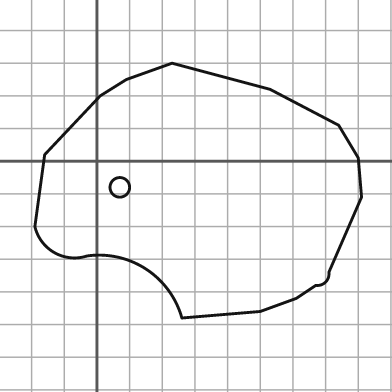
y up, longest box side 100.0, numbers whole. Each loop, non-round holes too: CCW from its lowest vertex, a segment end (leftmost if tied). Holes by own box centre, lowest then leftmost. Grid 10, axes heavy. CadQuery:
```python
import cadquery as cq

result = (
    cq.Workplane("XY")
    .moveTo(26.0, -48.0)
    .lineTo(50.0, -46.0)
    .lineTo(61.0, -42.0)
    .lineTo(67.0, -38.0)
    .threePointArc((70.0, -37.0), (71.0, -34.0))
    .lineTo(81.0, -11.0)
    .lineTo(80.0, 1.0)
    .lineTo(74.0, 11.0)
    .lineTo(53.0, 22.0)
    .lineTo(23.0, 30.0)
    .lineTo(9.0, 25.0)
    .lineTo(1.0, 20.0)
    .lineTo(-16.0, 2.0)
    .lineTo(-19.0, -20.0)
    .threePointArc((-13.0, -28.0), (-3.0, -29.0))
    .threePointArc((15.0, -33.0), (26.0, -48.0))
    .close()
    .moveTo(7.0, -8.0)
    .circle(3.0)
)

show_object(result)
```